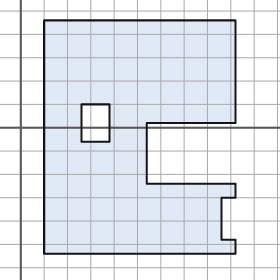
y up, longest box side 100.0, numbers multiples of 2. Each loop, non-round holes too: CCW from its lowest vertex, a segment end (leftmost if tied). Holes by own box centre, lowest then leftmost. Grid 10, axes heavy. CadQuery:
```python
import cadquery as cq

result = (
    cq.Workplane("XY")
    .moveTo(10.0, -54.0)
    .lineTo(92.0, -54.0)
    .lineTo(92.0, -48.0)
    .lineTo(86.0, -48.0)
    .lineTo(86.0, -30.0)
    .lineTo(92.0, -30.0)
    .lineTo(92.0, -24.0)
    .lineTo(54.0, -24.0)
    .lineTo(54.0, 2.0)
    .lineTo(92.0, 2.0)
    .lineTo(92.0, 46.0)
    .lineTo(10.0, 46.0)
    .close()
    .moveTo(26.0, -6.0)
    .lineTo(38.0, -6.0)
    .lineTo(38.0, 10.0)
    .lineTo(26.0, 10.0)
    .close()
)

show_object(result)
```